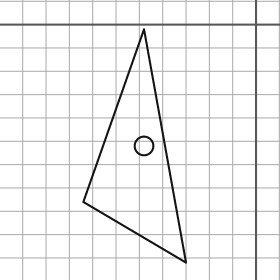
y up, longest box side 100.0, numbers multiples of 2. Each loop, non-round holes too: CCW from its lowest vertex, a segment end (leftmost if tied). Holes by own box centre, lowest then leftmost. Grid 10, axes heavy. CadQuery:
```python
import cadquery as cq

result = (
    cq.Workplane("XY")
    .moveTo(-30.0, -102.0)
    .lineTo(-48.0, -2.0)
    .lineTo(-74.0, -76.0)
    .close()
    .moveTo(-48.0, -52.0)
    .circle(4.0)
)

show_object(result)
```